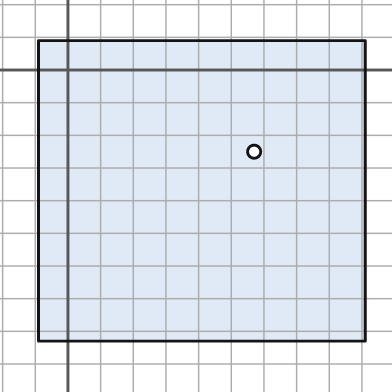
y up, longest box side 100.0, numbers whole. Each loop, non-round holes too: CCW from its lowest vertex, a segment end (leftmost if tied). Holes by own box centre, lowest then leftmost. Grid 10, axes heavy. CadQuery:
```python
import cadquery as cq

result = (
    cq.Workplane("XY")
    .moveTo(-9.0, -83.0)
    .lineTo(91.0, -83.0)
    .lineTo(91.0, 9.0)
    .lineTo(-9.0, 9.0)
    .close()
    .moveTo(57.0, -25.0)
    .circle(2.0)
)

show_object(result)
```